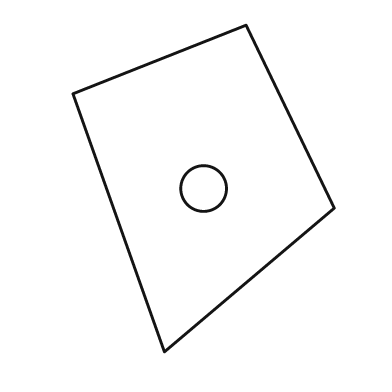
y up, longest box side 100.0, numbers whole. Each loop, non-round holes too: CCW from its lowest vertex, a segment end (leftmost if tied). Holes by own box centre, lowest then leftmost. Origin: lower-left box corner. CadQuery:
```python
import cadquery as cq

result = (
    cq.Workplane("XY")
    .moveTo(28.0, 0.0)
    .lineTo(80.0, 44.0)
    .lineTo(53.0, 100.0)
    .lineTo(0.0, 79.0)
    .close()
    .moveTo(40.0, 50.0)
    .circle(7.0)
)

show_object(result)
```